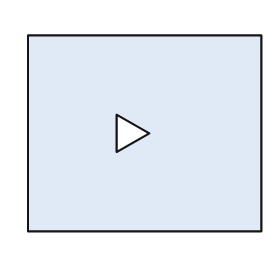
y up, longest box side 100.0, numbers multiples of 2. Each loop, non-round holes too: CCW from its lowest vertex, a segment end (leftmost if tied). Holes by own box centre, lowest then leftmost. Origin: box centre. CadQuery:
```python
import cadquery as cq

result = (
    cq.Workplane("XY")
    .moveTo(-50.0, -42.0)
    .lineTo(50.0, -42.0)
    .lineTo(50.0, 42.0)
    .lineTo(-50.0, 42.0)
    .close()
    .moveTo(-12.0, -8.0)
    .lineTo(2.0, 0.0)
    .lineTo(-12.0, 8.0)
    .close()
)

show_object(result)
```